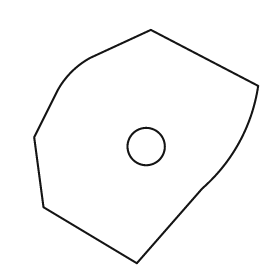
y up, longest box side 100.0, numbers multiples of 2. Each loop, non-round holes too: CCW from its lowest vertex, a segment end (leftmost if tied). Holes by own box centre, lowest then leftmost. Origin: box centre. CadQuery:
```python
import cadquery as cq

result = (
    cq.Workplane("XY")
    .moveTo(-4.0, -50.0)
    .lineTo(24.0, -18.0)
    .threePointArc((40.0, 2.0), (48.0, 26.0))
    .lineTo(2.0, 50.0)
    .lineTo(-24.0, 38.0)
    .threePointArc((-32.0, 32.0), (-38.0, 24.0))
    .lineTo(-48.0, 4.0)
    .lineTo(-44.0, -26.0)
    .close()
    .moveTo(0.0, 0.0)
    .circle(8.0)
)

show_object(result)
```